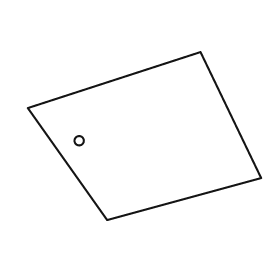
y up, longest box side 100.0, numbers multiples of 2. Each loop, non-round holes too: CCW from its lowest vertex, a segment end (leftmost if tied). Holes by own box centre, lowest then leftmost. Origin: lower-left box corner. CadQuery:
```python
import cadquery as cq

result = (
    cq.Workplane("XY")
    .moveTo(34.0, 0.0)
    .lineTo(100.0, 18.0)
    .lineTo(74.0, 72.0)
    .lineTo(0.0, 48.0)
    .close()
    .moveTo(22.0, 34.0)
    .circle(2.0)
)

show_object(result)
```